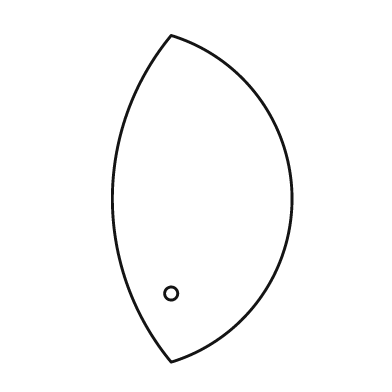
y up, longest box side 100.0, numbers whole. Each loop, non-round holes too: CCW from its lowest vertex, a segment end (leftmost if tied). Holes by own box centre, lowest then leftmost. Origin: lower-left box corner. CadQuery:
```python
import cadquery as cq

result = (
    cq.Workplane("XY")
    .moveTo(18.0, 0.0)
    .threePointArc((55.0, 50.0), (18.0, 100.0))
    .threePointArc((0.0, 50.0), (18.0, 0.0))
    .close()
    .moveTo(18.0, 21.0)
    .circle(2.0)
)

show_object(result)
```